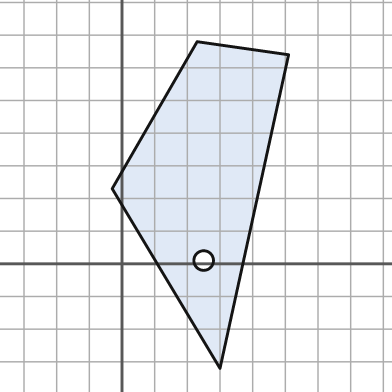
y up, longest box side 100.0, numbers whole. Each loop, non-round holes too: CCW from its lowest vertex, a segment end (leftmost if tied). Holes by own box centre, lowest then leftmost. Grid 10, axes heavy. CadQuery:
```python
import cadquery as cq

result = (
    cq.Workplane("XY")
    .moveTo(30.0, -32.0)
    .lineTo(51.0, 64.0)
    .lineTo(23.0, 68.0)
    .lineTo(-3.0, 23.0)
    .close()
    .moveTo(25.0, 1.0)
    .circle(3.0)
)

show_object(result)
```